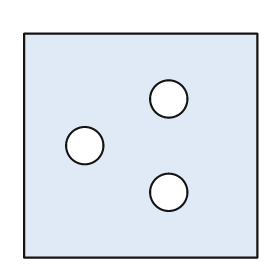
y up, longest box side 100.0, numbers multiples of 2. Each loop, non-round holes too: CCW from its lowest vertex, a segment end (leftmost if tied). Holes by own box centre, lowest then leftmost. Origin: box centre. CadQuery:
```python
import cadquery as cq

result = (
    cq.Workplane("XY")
    .moveTo(-50.0, -48.0)
    .lineTo(50.0, -48.0)
    .lineTo(50.0, 48.0)
    .lineTo(-50.0, 48.0)
    .close()
    .moveTo(12.0, -20.0)
    .circle(8.0)
    .moveTo(-24.0, 0.0)
    .circle(8.0)
    .moveTo(12.0, 20.0)
    .circle(8.0)
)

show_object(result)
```